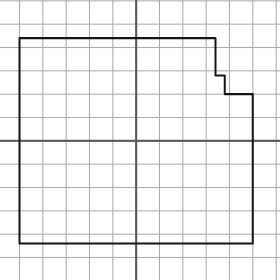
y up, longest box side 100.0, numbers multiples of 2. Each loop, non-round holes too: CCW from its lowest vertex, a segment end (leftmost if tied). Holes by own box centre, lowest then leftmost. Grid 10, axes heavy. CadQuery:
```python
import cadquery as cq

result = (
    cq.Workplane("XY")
    .moveTo(-50.0, -44.0)
    .lineTo(50.0, -44.0)
    .lineTo(50.0, 20.0)
    .lineTo(38.0, 20.0)
    .lineTo(38.0, 28.0)
    .lineTo(34.0, 28.0)
    .lineTo(34.0, 44.0)
    .lineTo(-50.0, 44.0)
    .close()
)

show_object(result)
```